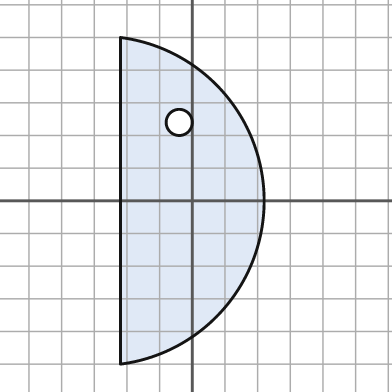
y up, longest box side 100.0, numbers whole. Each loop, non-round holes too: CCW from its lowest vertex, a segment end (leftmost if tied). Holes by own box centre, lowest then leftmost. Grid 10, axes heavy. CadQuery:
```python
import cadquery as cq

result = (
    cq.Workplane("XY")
    .moveTo(-22.0, -50.0)
    .threePointArc((22.0, 0.0), (-22.0, 50.0))
    .close()
    .moveTo(-4.0, 24.0)
    .circle(4.0)
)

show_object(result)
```